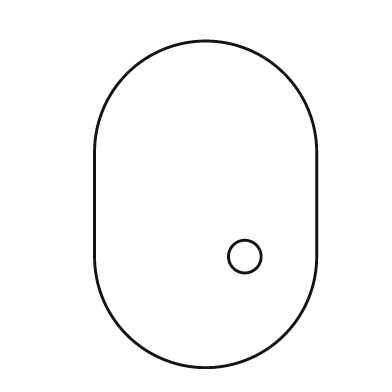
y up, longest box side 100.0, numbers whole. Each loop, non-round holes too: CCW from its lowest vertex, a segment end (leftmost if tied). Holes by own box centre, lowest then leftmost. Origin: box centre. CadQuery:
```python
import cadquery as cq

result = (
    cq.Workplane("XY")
    .moveTo(-34.0, -16.0)
    .threePointArc((0.0, -50.0), (34.0, -16.0))
    .lineTo(34.0, 16.0)
    .threePointArc((0.0, 50.0), (-34.0, 16.0))
    .close()
    .moveTo(12.0, -16.0)
    .circle(5.0)
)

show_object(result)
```